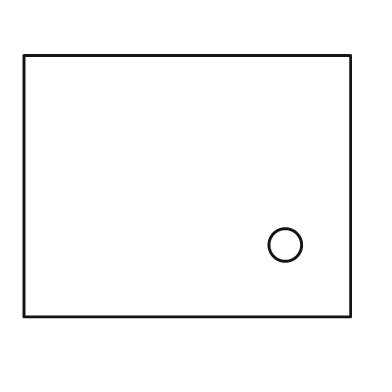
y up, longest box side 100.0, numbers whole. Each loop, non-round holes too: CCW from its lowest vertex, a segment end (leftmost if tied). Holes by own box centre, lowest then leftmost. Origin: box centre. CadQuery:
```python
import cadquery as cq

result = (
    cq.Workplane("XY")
    .moveTo(-50.0, -40.0)
    .lineTo(50.0, -40.0)
    .lineTo(50.0, 40.0)
    .lineTo(-50.0, 40.0)
    .close()
    .moveTo(30.0, -18.0)
    .circle(5.0)
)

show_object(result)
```